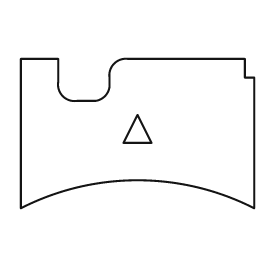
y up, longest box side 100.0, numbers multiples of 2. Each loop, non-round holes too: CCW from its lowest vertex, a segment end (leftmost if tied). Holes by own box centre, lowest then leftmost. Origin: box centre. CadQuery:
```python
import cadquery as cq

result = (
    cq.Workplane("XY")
    .moveTo(-50.0, -32.0)
    .threePointArc((0.0, -20.0), (50.0, -32.0))
    .lineTo(50.0, 24.0)
    .lineTo(46.0, 24.0)
    .lineTo(46.0, 32.0)
    .lineTo(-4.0, 32.0)
    .threePointArc((-10.0, 30.0), (-12.0, 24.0))
    .lineTo(-12.0, 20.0)
    .threePointArc((-14.0, 16.0), (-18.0, 14.0))
    .lineTo(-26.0, 14.0)
    .threePointArc((-32.0, 16.0), (-34.0, 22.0))
    .lineTo(-34.0, 32.0)
    .lineTo(-50.0, 32.0)
    .close()
    .moveTo(-6.0, -4.0)
    .lineTo(6.0, -4.0)
    .lineTo(0.0, 8.0)
    .close()
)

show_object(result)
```